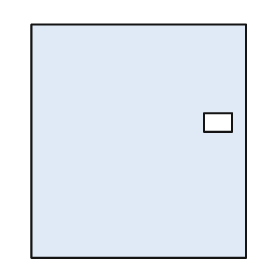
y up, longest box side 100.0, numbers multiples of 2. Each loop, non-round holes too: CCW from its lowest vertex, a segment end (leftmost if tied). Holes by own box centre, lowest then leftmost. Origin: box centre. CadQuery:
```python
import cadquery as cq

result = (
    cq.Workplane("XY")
    .moveTo(-46.0, -50.0)
    .lineTo(46.0, -50.0)
    .lineTo(46.0, 50.0)
    .lineTo(-46.0, 50.0)
    .close()
    .moveTo(28.0, 4.0)
    .lineTo(40.0, 4.0)
    .lineTo(40.0, 12.0)
    .lineTo(28.0, 12.0)
    .close()
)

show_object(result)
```